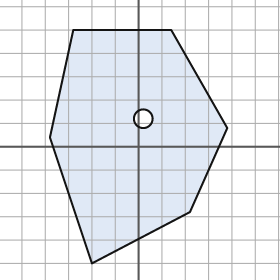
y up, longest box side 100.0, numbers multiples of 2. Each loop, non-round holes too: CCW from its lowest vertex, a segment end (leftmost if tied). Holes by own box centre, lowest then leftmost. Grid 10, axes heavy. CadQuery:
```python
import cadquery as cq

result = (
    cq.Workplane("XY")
    .moveTo(-20.0, -50.0)
    .lineTo(22.0, -28.0)
    .lineTo(38.0, 8.0)
    .lineTo(14.0, 50.0)
    .lineTo(-28.0, 50.0)
    .lineTo(-38.0, 4.0)
    .close()
    .moveTo(2.0, 12.0)
    .circle(4.0)
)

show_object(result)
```